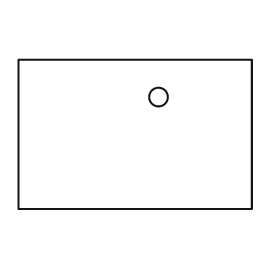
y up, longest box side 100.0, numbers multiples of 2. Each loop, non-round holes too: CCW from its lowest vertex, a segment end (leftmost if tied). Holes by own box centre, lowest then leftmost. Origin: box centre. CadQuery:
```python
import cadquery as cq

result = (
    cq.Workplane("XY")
    .moveTo(-50.0, -32.0)
    .lineTo(50.0, -32.0)
    .lineTo(50.0, 32.0)
    .lineTo(-50.0, 32.0)
    .close()
    .moveTo(10.0, 16.0)
    .circle(4.0)
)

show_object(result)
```